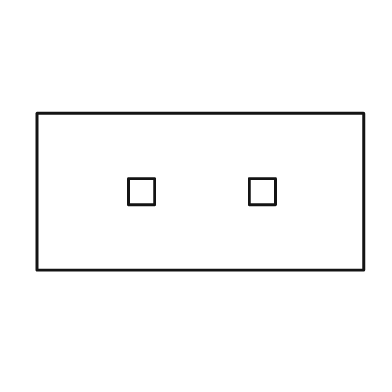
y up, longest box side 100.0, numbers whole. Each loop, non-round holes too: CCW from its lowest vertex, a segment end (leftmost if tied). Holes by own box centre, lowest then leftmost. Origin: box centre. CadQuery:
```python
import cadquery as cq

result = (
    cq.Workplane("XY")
    .moveTo(-50.0, -24.0)
    .lineTo(50.0, -24.0)
    .lineTo(50.0, 24.0)
    .lineTo(-50.0, 24.0)
    .close()
    .moveTo(-22.0, -4.0)
    .lineTo(-14.0, -4.0)
    .lineTo(-14.0, 4.0)
    .lineTo(-22.0, 4.0)
    .close()
    .moveTo(15.0, -4.0)
    .lineTo(23.0, -4.0)
    .lineTo(23.0, 4.0)
    .lineTo(15.0, 4.0)
    .close()
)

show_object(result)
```